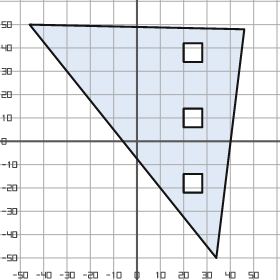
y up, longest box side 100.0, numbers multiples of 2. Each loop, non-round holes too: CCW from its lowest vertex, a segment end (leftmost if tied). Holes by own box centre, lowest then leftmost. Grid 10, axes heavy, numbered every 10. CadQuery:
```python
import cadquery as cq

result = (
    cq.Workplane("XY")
    .moveTo(34.0, -50.0)
    .lineTo(46.0, 48.0)
    .lineTo(-46.0, 50.0)
    .close()
    .moveTo(20.0, -22.0)
    .lineTo(28.0, -22.0)
    .lineTo(28.0, -14.0)
    .lineTo(20.0, -14.0)
    .close()
    .moveTo(20.0, 6.0)
    .lineTo(28.0, 6.0)
    .lineTo(28.0, 14.0)
    .lineTo(20.0, 14.0)
    .close()
    .moveTo(20.0, 34.0)
    .lineTo(28.0, 34.0)
    .lineTo(28.0, 42.0)
    .lineTo(20.0, 42.0)
    .close()
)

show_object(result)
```